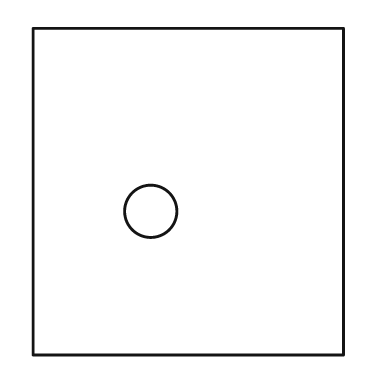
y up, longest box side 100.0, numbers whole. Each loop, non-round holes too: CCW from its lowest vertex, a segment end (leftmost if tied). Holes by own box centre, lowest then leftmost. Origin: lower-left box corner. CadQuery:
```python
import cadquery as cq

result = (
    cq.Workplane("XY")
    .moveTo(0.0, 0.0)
    .lineTo(95.0, 0.0)
    .lineTo(95.0, 100.0)
    .lineTo(0.0, 100.0)
    .close()
    .moveTo(36.0, 44.0)
    .circle(8.0)
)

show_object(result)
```